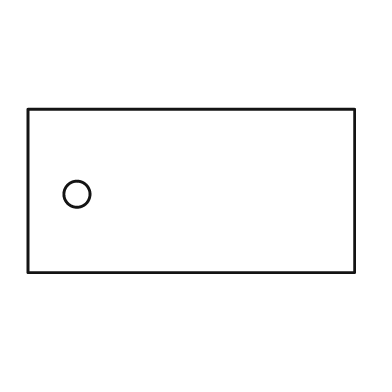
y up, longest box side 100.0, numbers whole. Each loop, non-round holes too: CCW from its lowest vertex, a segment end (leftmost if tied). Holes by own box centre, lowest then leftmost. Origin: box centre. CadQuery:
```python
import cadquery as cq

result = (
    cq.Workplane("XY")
    .moveTo(-50.0, -25.0)
    .lineTo(50.0, -25.0)
    .lineTo(50.0, 25.0)
    .lineTo(-50.0, 25.0)
    .close()
    .moveTo(-35.0, -1.0)
    .circle(4.0)
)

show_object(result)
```